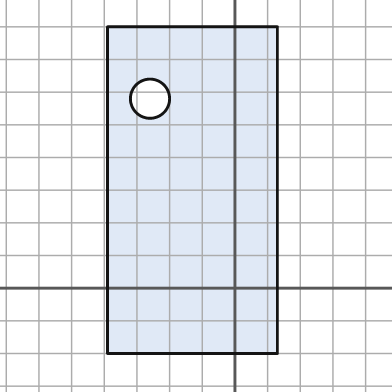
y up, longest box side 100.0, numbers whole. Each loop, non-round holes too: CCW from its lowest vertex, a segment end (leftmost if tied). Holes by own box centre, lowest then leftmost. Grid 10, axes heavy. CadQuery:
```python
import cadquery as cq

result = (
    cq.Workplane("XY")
    .moveTo(-39.0, -20.0)
    .lineTo(13.0, -20.0)
    .lineTo(13.0, 80.0)
    .lineTo(-39.0, 80.0)
    .close()
    .moveTo(-26.0, 58.0)
    .circle(6.0)
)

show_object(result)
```